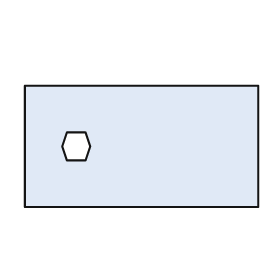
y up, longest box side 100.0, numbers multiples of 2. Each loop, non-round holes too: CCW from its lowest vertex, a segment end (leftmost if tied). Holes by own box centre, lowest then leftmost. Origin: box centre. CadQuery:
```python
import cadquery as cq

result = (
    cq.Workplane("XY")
    .moveTo(-50.0, -26.0)
    .lineTo(50.0, -26.0)
    .lineTo(50.0, 26.0)
    .lineTo(-50.0, 26.0)
    .close()
    .moveTo(-32.0, -6.0)
    .lineTo(-24.0, -6.0)
    .lineTo(-22.0, 0.0)
    .lineTo(-24.0, 6.0)
    .lineTo(-32.0, 6.0)
    .lineTo(-34.0, 0.0)
    .close()
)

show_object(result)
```